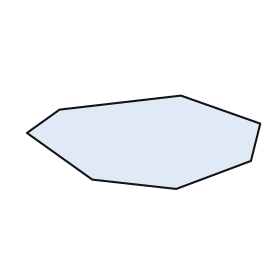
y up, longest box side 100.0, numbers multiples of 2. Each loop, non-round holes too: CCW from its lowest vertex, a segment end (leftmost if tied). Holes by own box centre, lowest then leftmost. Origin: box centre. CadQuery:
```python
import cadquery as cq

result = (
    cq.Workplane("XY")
    .moveTo(14.0, -20.0)
    .lineTo(46.0, -8.0)
    .lineTo(50.0, 8.0)
    .lineTo(16.0, 20.0)
    .lineTo(-36.0, 14.0)
    .lineTo(-50.0, 4.0)
    .lineTo(-22.0, -16.0)
    .close()
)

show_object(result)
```